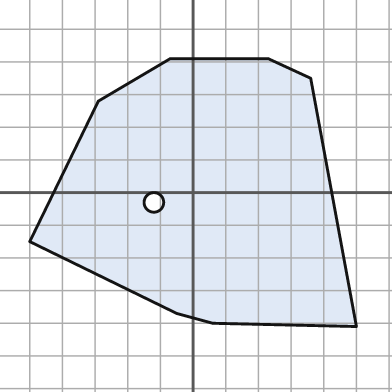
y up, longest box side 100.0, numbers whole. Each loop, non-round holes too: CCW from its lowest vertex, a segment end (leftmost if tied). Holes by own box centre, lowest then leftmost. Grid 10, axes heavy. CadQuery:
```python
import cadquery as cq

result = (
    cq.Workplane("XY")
    .moveTo(50.0, -41.0)
    .lineTo(36.0, 35.0)
    .lineTo(23.0, 41.0)
    .lineTo(-7.0, 41.0)
    .lineTo(-29.0, 28.0)
    .lineTo(-50.0, -15.0)
    .lineTo(-5.0, -37.0)
    .lineTo(6.0, -40.0)
    .close()
    .moveTo(-12.0, -3.0)
    .circle(3.0)
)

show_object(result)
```